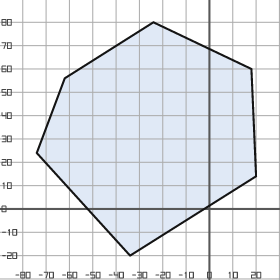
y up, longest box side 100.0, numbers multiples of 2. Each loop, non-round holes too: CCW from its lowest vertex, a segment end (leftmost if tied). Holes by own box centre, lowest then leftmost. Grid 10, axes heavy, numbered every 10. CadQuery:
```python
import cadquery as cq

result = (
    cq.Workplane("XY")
    .moveTo(-34.0, -20.0)
    .lineTo(20.0, 14.0)
    .lineTo(18.0, 60.0)
    .lineTo(-24.0, 80.0)
    .lineTo(-62.0, 56.0)
    .lineTo(-74.0, 24.0)
    .close()
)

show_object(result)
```